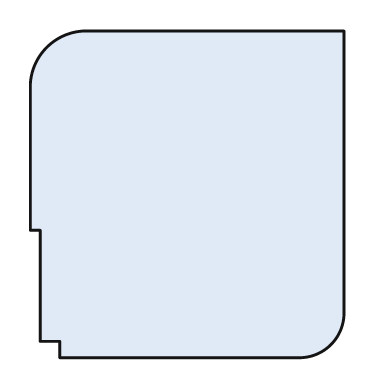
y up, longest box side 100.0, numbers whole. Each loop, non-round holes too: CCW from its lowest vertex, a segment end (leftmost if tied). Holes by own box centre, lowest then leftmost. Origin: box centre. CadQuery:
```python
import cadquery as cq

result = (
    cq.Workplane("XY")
    .moveTo(-39.0, -50.0)
    .lineTo(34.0, -50.0)
    .threePointArc((44.0, -46.0), (48.0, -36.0))
    .lineTo(48.0, 50.0)
    .lineTo(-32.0, 50.0)
    .threePointArc((-43.0, 45.0), (-48.0, 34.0))
    .lineTo(-48.0, -11.0)
    .lineTo(-45.0, -11.0)
    .lineTo(-45.0, -45.0)
    .lineTo(-39.0, -45.0)
    .close()
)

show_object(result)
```